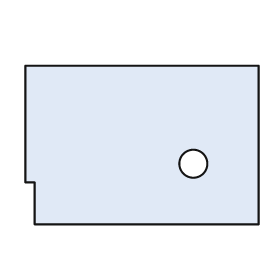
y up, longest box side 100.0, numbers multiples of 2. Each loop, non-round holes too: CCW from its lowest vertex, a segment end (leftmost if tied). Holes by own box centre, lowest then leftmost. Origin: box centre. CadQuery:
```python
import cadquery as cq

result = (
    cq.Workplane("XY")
    .moveTo(-46.0, -34.0)
    .lineTo(50.0, -34.0)
    .lineTo(50.0, 34.0)
    .lineTo(-50.0, 34.0)
    .lineTo(-50.0, -16.0)
    .lineTo(-46.0, -16.0)
    .close()
    .moveTo(22.0, -8.0)
    .circle(6.0)
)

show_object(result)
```